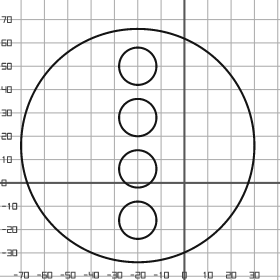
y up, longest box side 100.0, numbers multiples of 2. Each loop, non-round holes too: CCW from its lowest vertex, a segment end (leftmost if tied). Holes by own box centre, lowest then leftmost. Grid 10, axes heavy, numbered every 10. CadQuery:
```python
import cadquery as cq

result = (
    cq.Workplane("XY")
    .moveTo(-20.0, 16.0)
    .circle(50.0)
    .moveTo(-20.0, -16.0)
    .circle(8.0)
    .moveTo(-20.0, 6.0)
    .circle(8.0)
    .moveTo(-20.0, 28.0)
    .circle(8.0)
    .moveTo(-20.0, 50.0)
    .circle(8.0)
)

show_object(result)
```